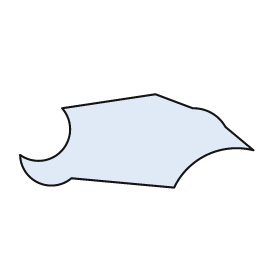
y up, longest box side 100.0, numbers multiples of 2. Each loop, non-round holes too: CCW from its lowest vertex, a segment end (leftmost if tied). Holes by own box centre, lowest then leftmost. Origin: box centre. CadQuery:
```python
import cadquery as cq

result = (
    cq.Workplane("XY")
    .moveTo(16.0, -20.0)
    .threePointArc((30.0, -6.0), (50.0, -4.0))
    .lineTo(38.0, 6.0)
    .threePointArc((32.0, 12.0), (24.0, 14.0))
    .lineTo(8.0, 20.0)
    .lineTo(-32.0, 14.0)
    .threePointArc((-32.0, -4.0), (-50.0, -6.0))
    .threePointArc((-42.0, -18.0), (-28.0, -16.0))
    .close()
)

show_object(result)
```